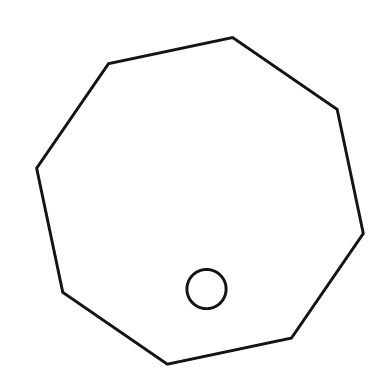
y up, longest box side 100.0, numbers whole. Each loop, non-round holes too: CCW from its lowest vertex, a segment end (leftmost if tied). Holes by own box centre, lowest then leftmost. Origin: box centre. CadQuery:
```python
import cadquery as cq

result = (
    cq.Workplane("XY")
    .moveTo(-10.0, -50.0)
    .lineTo(28.0, -42.0)
    .lineTo(50.0, -10.0)
    .lineTo(42.0, 28.0)
    .lineTo(10.0, 50.0)
    .lineTo(-28.0, 42.0)
    .lineTo(-50.0, 10.0)
    .lineTo(-42.0, -28.0)
    .close()
    .moveTo(2.0, -27.0)
    .circle(6.0)
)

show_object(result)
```